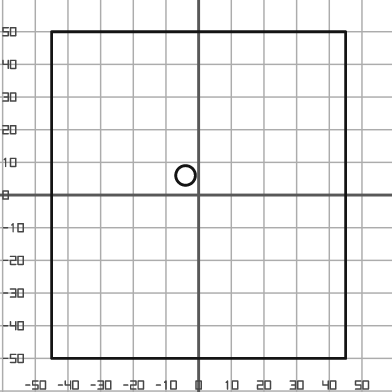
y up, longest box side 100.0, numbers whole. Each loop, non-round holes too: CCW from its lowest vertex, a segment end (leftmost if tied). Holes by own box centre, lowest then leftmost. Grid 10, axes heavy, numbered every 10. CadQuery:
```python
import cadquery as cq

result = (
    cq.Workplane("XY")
    .moveTo(-45.0, -50.0)
    .lineTo(45.0, -50.0)
    .lineTo(45.0, 50.0)
    .lineTo(-45.0, 50.0)
    .close()
    .moveTo(-4.0, 6.0)
    .circle(3.0)
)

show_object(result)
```